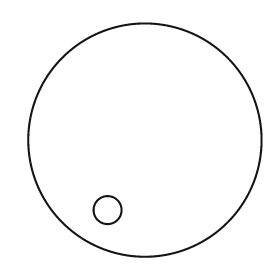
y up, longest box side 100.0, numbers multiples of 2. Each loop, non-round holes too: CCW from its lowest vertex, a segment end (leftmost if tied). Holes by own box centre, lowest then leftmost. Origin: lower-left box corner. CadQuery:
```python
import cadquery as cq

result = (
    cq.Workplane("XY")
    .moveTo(50.0, 50.0)
    .circle(50.0)
    .moveTo(34.0, 20.0)
    .circle(6.0)
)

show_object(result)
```